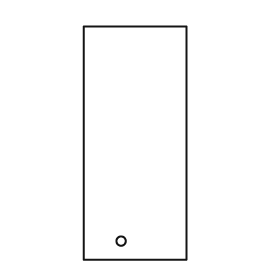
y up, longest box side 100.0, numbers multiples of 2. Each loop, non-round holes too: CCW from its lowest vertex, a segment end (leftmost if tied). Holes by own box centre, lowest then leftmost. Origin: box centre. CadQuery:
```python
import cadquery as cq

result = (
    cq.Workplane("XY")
    .moveTo(-22.0, -50.0)
    .lineTo(22.0, -50.0)
    .lineTo(22.0, 50.0)
    .lineTo(-22.0, 50.0)
    .close()
    .moveTo(-6.0, -42.0)
    .circle(2.0)
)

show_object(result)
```